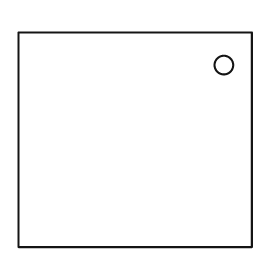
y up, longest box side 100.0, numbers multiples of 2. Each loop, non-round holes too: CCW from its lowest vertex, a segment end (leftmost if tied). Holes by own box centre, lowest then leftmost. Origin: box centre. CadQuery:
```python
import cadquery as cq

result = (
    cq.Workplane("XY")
    .moveTo(-50.0, -46.0)
    .lineTo(50.0, -46.0)
    .lineTo(50.0, 46.0)
    .lineTo(-50.0, 46.0)
    .close()
    .moveTo(38.0, 32.0)
    .circle(4.0)
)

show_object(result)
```